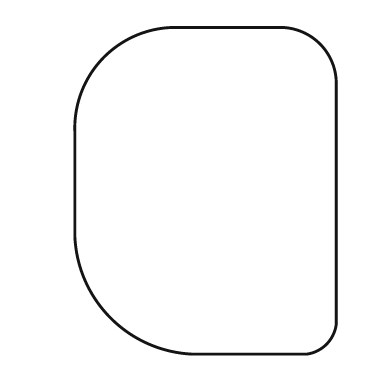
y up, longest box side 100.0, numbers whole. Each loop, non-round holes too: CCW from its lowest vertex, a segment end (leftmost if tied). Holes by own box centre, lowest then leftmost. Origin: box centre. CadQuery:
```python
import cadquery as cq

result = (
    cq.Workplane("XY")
    .moveTo(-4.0, -50.0)
    .lineTo(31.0, -50.0)
    .threePointArc((37.0, -47.0), (40.0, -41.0))
    .lineTo(40.0, 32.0)
    .threePointArc((35.0, 45.0), (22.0, 50.0))
    .lineTo(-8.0, 50.0)
    .threePointArc((-31.0, 41.0), (-40.0, 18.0))
    .lineTo(-40.0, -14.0)
    .threePointArc((-29.0, -39.0), (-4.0, -50.0))
    .close()
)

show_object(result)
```